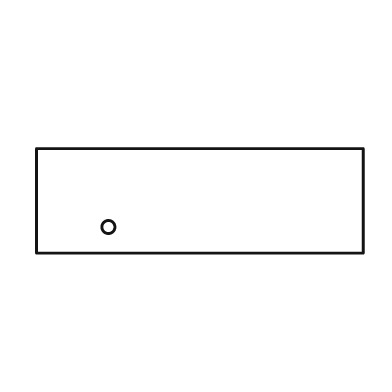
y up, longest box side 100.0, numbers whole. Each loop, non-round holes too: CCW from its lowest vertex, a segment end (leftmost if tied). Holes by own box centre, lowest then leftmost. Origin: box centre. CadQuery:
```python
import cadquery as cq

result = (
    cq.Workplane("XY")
    .moveTo(-50.0, -16.0)
    .lineTo(50.0, -16.0)
    .lineTo(50.0, 16.0)
    .lineTo(-50.0, 16.0)
    .close()
    .moveTo(-28.0, -8.0)
    .circle(2.0)
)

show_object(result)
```